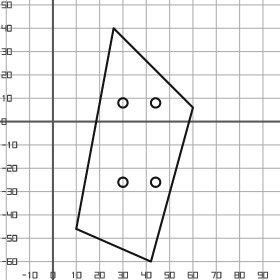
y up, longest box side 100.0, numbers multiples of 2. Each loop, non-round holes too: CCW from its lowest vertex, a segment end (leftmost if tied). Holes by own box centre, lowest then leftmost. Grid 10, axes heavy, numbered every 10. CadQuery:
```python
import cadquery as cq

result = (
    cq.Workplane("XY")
    .moveTo(42.0, -60.0)
    .lineTo(60.0, 6.0)
    .lineTo(26.0, 40.0)
    .lineTo(10.0, -46.0)
    .close()
    .moveTo(30.0, -26.0)
    .circle(2.0)
    .moveTo(44.0, -26.0)
    .circle(2.0)
    .moveTo(30.0, 8.0)
    .circle(2.0)
    .moveTo(44.0, 8.0)
    .circle(2.0)
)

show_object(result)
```